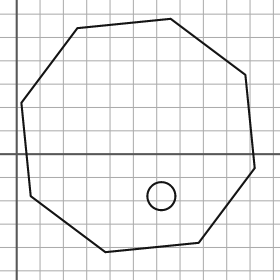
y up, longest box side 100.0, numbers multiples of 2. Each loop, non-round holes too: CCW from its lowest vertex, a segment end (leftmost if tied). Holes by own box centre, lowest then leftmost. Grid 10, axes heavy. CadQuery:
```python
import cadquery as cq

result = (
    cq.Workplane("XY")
    .moveTo(38.0, -42.0)
    .lineTo(78.0, -38.0)
    .lineTo(102.0, -6.0)
    .lineTo(98.0, 34.0)
    .lineTo(66.0, 58.0)
    .lineTo(26.0, 54.0)
    .lineTo(2.0, 22.0)
    .lineTo(6.0, -18.0)
    .close()
    .moveTo(62.0, -18.0)
    .circle(6.0)
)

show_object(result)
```